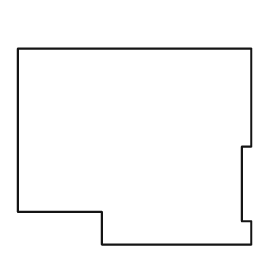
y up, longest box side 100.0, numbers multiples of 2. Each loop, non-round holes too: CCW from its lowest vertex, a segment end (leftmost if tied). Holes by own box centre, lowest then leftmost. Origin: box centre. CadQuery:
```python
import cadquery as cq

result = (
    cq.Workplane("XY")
    .moveTo(-14.0, -42.0)
    .lineTo(50.0, -42.0)
    .lineTo(50.0, -32.0)
    .lineTo(46.0, -32.0)
    .lineTo(46.0, 0.0)
    .lineTo(50.0, 0.0)
    .lineTo(50.0, 42.0)
    .lineTo(-50.0, 42.0)
    .lineTo(-50.0, -28.0)
    .lineTo(-14.0, -28.0)
    .close()
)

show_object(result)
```